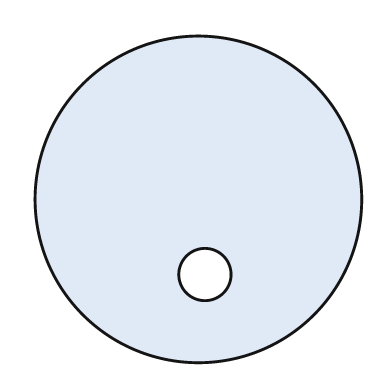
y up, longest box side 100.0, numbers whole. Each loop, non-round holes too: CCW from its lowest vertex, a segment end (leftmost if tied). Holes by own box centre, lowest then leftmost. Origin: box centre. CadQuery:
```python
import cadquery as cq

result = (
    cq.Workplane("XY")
    .moveTo(0.0, 0.0)
    .circle(50.0)
    .moveTo(2.0, -23.0)
    .circle(8.0)
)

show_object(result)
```